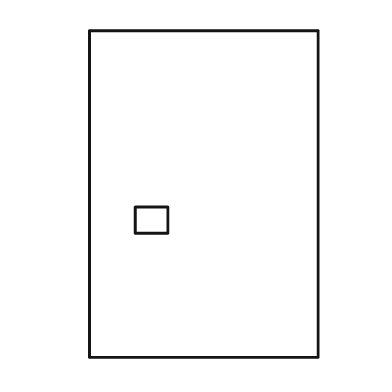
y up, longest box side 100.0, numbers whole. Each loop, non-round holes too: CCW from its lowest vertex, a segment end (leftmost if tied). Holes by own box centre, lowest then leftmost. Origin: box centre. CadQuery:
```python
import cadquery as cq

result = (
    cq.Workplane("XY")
    .moveTo(-35.0, -50.0)
    .lineTo(35.0, -50.0)
    .lineTo(35.0, 50.0)
    .lineTo(-35.0, 50.0)
    .close()
    .moveTo(-21.0, -12.0)
    .lineTo(-11.0, -12.0)
    .lineTo(-11.0, -4.0)
    .lineTo(-21.0, -4.0)
    .close()
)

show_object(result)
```